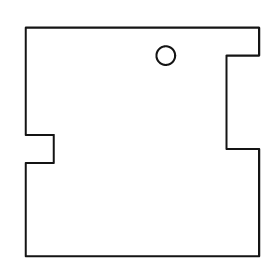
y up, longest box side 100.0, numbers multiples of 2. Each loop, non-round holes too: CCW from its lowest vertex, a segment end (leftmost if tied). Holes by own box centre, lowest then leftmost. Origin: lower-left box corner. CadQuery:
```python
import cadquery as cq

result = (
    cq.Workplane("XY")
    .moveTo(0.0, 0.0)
    .lineTo(100.0, 0.0)
    .lineTo(100.0, 46.0)
    .lineTo(86.0, 46.0)
    .lineTo(86.0, 86.0)
    .lineTo(100.0, 86.0)
    .lineTo(100.0, 98.0)
    .lineTo(0.0, 98.0)
    .lineTo(0.0, 52.0)
    .lineTo(12.0, 52.0)
    .lineTo(12.0, 40.0)
    .lineTo(0.0, 40.0)
    .close()
    .moveTo(60.0, 86.0)
    .circle(4.0)
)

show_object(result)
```